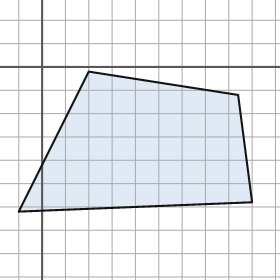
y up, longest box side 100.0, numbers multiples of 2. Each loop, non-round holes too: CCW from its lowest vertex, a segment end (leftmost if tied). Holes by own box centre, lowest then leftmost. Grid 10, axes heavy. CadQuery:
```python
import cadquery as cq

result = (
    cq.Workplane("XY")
    .moveTo(-10.0, -62.0)
    .lineTo(90.0, -58.0)
    .lineTo(84.0, -12.0)
    .lineTo(20.0, -2.0)
    .close()
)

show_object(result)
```